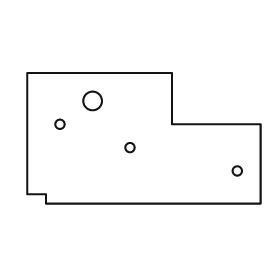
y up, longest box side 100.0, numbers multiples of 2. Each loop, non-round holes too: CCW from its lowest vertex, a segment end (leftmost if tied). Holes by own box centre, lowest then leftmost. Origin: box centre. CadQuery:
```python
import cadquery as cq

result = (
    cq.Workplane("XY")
    .moveTo(-42.0, -28.0)
    .lineTo(50.0, -28.0)
    .lineTo(50.0, 6.0)
    .lineTo(12.0, 6.0)
    .lineTo(12.0, 28.0)
    .lineTo(-50.0, 28.0)
    .lineTo(-50.0, -24.0)
    .lineTo(-42.0, -24.0)
    .close()
    .moveTo(40.0, -14.0)
    .circle(2.0)
    .moveTo(-6.0, -4.0)
    .circle(2.0)
    .moveTo(-36.0, 6.0)
    .circle(2.0)
    .moveTo(-22.0, 16.0)
    .circle(4.0)
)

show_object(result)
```